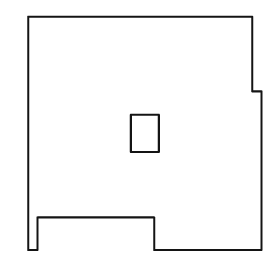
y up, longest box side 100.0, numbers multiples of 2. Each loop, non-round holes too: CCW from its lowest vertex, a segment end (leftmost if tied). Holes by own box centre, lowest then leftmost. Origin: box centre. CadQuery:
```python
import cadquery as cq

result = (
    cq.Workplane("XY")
    .moveTo(-50.0, -50.0)
    .lineTo(-46.0, -50.0)
    .lineTo(-46.0, -36.0)
    .lineTo(4.0, -36.0)
    .lineTo(4.0, -50.0)
    .lineTo(50.0, -50.0)
    .lineTo(50.0, 18.0)
    .lineTo(46.0, 18.0)
    .lineTo(46.0, 50.0)
    .lineTo(-50.0, 50.0)
    .close()
    .moveTo(-6.0, -8.0)
    .lineTo(6.0, -8.0)
    .lineTo(6.0, 8.0)
    .lineTo(-6.0, 8.0)
    .close()
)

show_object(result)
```